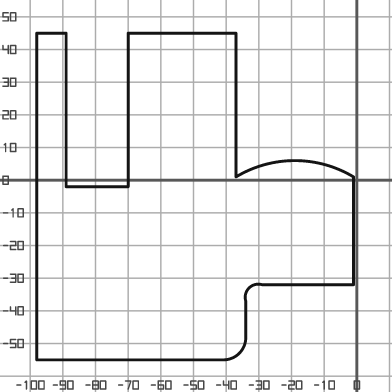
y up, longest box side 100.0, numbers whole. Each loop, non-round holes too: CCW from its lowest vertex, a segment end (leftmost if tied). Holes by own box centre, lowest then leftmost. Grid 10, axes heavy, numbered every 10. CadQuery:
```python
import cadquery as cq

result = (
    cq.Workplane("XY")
    .moveTo(-98.0, -55.0)
    .lineTo(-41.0, -55.0)
    .threePointArc((-36.0, -53.0), (-34.0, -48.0))
    .lineTo(-34.0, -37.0)
    .threePointArc((-33.0, -33.0), (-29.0, -32.0))
    .lineTo(-1.0, -32.0)
    .lineTo(-1.0, 1.0)
    .threePointArc((-19.0, 6.0), (-37.0, 1.0))
    .lineTo(-37.0, 45.0)
    .lineTo(-70.0, 45.0)
    .lineTo(-70.0, -2.0)
    .lineTo(-89.0, -2.0)
    .lineTo(-89.0, 45.0)
    .lineTo(-98.0, 45.0)
    .close()
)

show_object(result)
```